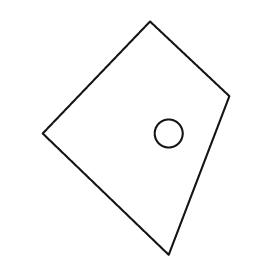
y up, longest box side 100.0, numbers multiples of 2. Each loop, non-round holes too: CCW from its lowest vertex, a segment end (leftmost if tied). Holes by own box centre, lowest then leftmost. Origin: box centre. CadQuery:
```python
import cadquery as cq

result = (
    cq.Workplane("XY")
    .moveTo(14.0, -50.0)
    .lineTo(40.0, 18.0)
    .lineTo(6.0, 50.0)
    .lineTo(-40.0, 2.0)
    .close()
    .moveTo(14.0, 2.0)
    .circle(6.0)
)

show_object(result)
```